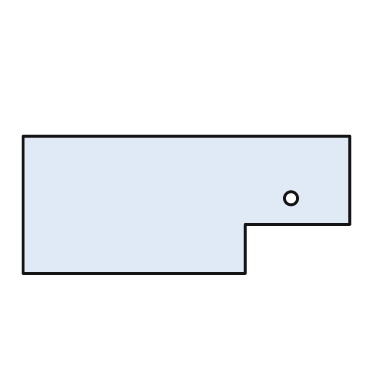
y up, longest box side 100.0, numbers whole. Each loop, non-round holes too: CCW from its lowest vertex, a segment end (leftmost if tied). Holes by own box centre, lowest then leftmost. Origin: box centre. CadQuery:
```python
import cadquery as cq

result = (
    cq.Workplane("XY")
    .moveTo(-50.0, -21.0)
    .lineTo(18.0, -21.0)
    .lineTo(18.0, -6.0)
    .lineTo(50.0, -6.0)
    .lineTo(50.0, 21.0)
    .lineTo(-50.0, 21.0)
    .close()
    .moveTo(32.0, 2.0)
    .circle(2.0)
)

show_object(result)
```